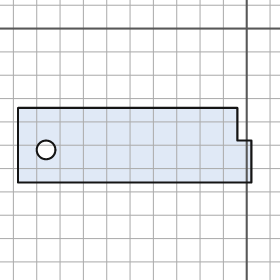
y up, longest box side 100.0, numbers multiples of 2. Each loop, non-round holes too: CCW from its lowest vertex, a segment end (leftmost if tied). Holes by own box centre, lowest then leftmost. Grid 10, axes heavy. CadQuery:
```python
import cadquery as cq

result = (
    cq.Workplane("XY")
    .moveTo(-98.0, -66.0)
    .lineTo(2.0, -66.0)
    .lineTo(2.0, -48.0)
    .lineTo(-4.0, -48.0)
    .lineTo(-4.0, -34.0)
    .lineTo(-98.0, -34.0)
    .close()
    .moveTo(-86.0, -52.0)
    .circle(4.0)
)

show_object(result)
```